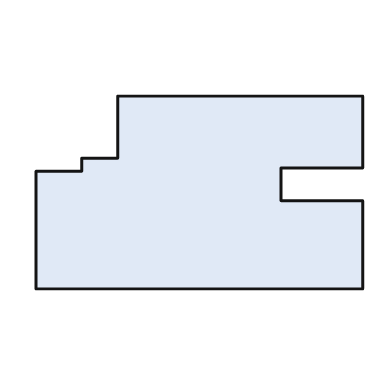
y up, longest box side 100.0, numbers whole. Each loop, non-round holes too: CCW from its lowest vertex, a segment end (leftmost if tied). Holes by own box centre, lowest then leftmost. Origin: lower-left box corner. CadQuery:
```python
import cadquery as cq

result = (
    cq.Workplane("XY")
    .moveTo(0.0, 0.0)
    .lineTo(100.0, 0.0)
    .lineTo(100.0, 27.0)
    .lineTo(75.0, 27.0)
    .lineTo(75.0, 37.0)
    .lineTo(100.0, 37.0)
    .lineTo(100.0, 59.0)
    .lineTo(25.0, 59.0)
    .lineTo(25.0, 40.0)
    .lineTo(14.0, 40.0)
    .lineTo(14.0, 36.0)
    .lineTo(0.0, 36.0)
    .close()
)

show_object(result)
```